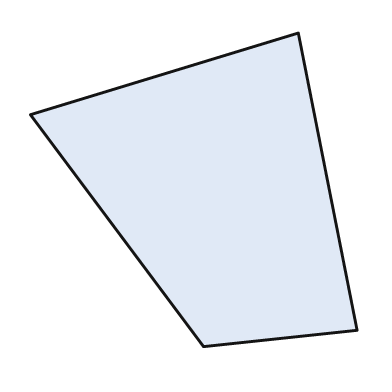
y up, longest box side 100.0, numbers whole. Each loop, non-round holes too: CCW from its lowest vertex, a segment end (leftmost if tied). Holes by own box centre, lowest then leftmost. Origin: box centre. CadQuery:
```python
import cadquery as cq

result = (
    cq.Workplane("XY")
    .moveTo(3.0, -48.0)
    .lineTo(50.0, -43.0)
    .lineTo(32.0, 48.0)
    .lineTo(-50.0, 23.0)
    .close()
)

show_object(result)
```